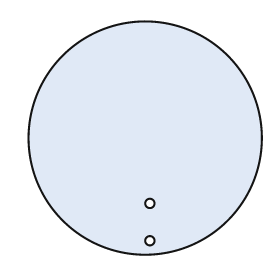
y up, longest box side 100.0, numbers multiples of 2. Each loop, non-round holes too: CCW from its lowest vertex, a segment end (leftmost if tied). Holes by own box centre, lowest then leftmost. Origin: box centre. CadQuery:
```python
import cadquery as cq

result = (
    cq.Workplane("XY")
    .moveTo(0.0, 0.0)
    .circle(50.0)
    .moveTo(2.0, -44.0)
    .circle(2.0)
    .moveTo(2.0, -28.0)
    .circle(2.0)
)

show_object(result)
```